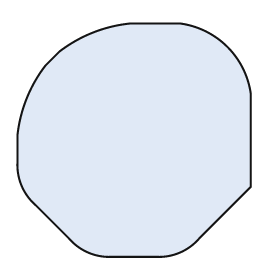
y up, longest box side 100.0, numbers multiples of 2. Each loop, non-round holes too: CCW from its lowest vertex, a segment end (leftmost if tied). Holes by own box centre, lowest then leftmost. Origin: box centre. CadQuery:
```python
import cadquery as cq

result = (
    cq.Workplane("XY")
    .moveTo(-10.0, -50.0)
    .lineTo(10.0, -50.0)
    .threePointArc((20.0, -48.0), (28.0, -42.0))
    .lineTo(50.0, -20.0)
    .lineTo(50.0, 20.0)
    .threePointArc((40.0, 40.0), (20.0, 50.0))
    .lineTo(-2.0, 50.0)
    .threePointArc((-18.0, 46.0), (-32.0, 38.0))
    .lineTo(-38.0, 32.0)
    .threePointArc((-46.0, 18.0), (-50.0, 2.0))
    .lineTo(-50.0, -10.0)
    .threePointArc((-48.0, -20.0), (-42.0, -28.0))
    .lineTo(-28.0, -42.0)
    .threePointArc((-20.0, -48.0), (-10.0, -50.0))
    .close()
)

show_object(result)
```